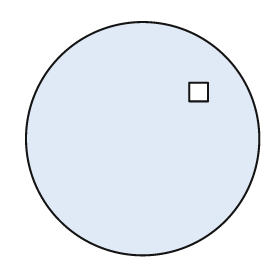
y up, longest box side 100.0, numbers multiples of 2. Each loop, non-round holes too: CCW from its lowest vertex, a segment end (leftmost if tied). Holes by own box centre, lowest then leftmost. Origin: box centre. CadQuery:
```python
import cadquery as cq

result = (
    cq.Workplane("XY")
    .moveTo(0.0, 0.0)
    .circle(50.0)
    .moveTo(20.0, 16.0)
    .lineTo(28.0, 16.0)
    .lineTo(28.0, 24.0)
    .lineTo(20.0, 24.0)
    .close()
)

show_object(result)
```